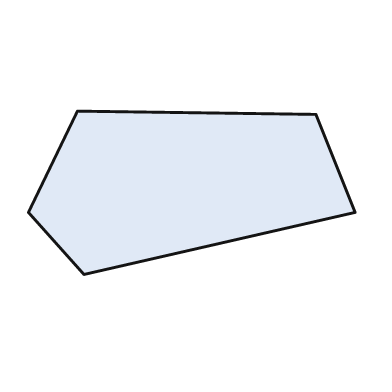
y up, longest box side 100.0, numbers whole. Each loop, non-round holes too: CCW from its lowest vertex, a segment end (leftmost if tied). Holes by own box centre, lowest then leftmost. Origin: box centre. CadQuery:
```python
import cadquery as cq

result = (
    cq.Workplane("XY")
    .moveTo(-33.0, -25.0)
    .lineTo(50.0, -6.0)
    .lineTo(38.0, 24.0)
    .lineTo(-35.0, 25.0)
    .lineTo(-50.0, -6.0)
    .close()
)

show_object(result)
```